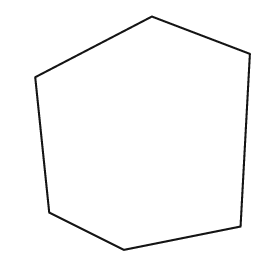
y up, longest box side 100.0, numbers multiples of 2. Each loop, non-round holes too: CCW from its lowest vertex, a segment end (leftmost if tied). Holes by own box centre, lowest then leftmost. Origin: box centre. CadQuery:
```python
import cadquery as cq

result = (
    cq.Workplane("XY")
    .moveTo(-8.0, -50.0)
    .lineTo(42.0, -40.0)
    .lineTo(46.0, 34.0)
    .lineTo(4.0, 50.0)
    .lineTo(-46.0, 24.0)
    .lineTo(-40.0, -34.0)
    .close()
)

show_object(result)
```